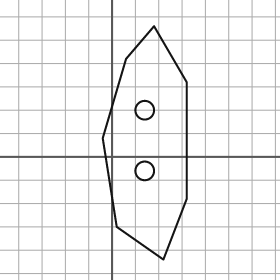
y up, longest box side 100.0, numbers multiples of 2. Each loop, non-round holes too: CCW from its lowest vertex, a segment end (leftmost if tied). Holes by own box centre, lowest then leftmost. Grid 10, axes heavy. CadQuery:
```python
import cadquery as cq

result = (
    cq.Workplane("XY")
    .moveTo(22.0, -44.0)
    .lineTo(32.0, -18.0)
    .lineTo(32.0, 32.0)
    .lineTo(18.0, 56.0)
    .lineTo(6.0, 42.0)
    .lineTo(-4.0, 8.0)
    .lineTo(2.0, -30.0)
    .close()
    .moveTo(14.0, -6.0)
    .circle(4.0)
    .moveTo(14.0, 20.0)
    .circle(4.0)
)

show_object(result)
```